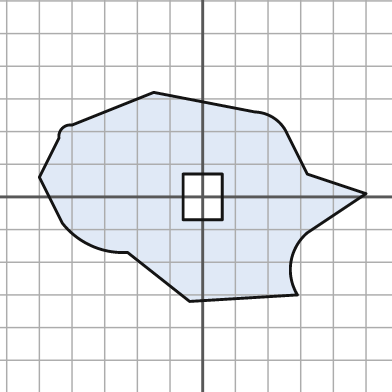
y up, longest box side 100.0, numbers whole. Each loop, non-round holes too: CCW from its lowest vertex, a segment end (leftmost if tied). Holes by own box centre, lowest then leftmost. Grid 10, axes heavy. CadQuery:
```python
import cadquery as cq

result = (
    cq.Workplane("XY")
    .moveTo(-4.0, -32.0)
    .lineTo(29.0, -30.0)
    .threePointArc((27.0, -20.0), (32.0, -11.0))
    .lineTo(50.0, 1.0)
    .lineTo(32.0, 7.0)
    .lineTo(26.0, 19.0)
    .threePointArc((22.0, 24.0), (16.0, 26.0))
    .lineTo(-15.0, 32.0)
    .lineTo(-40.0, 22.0)
    .threePointArc((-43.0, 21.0), (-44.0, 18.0))
    .lineTo(-50.0, 6.0)
    .lineTo(-43.0, -8.0)
    .threePointArc((-34.0, -15.0), (-23.0, -17.0))
    .close()
    .moveTo(-6.0, -7.0)
    .lineTo(6.0, -7.0)
    .lineTo(6.0, 7.0)
    .lineTo(-6.0, 7.0)
    .close()
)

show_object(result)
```